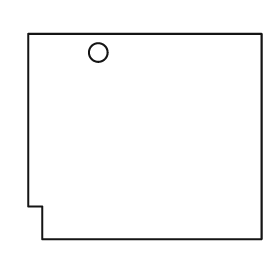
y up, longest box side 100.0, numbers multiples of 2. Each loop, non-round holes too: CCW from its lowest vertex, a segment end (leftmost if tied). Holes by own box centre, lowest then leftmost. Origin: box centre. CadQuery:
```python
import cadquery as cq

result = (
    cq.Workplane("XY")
    .moveTo(-44.0, -44.0)
    .lineTo(50.0, -44.0)
    .lineTo(50.0, 44.0)
    .lineTo(-50.0, 44.0)
    .lineTo(-50.0, -30.0)
    .lineTo(-44.0, -30.0)
    .close()
    .moveTo(-20.0, 36.0)
    .circle(4.0)
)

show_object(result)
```